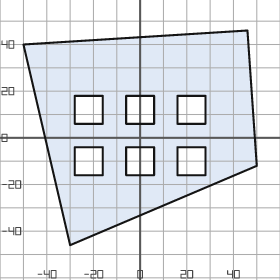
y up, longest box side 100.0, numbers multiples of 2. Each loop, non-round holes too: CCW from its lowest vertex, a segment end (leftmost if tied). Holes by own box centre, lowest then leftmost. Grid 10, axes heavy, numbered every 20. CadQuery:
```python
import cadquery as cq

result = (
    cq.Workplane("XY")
    .moveTo(-30.0, -46.0)
    .lineTo(50.0, -12.0)
    .lineTo(46.0, 46.0)
    .lineTo(-50.0, 40.0)
    .close()
    .moveTo(-28.0, -16.0)
    .lineTo(-16.0, -16.0)
    .lineTo(-16.0, -4.0)
    .lineTo(-28.0, -4.0)
    .close()
    .moveTo(-6.0, -16.0)
    .lineTo(6.0, -16.0)
    .lineTo(6.0, -4.0)
    .lineTo(-6.0, -4.0)
    .close()
    .moveTo(16.0, -16.0)
    .lineTo(28.0, -16.0)
    .lineTo(28.0, -4.0)
    .lineTo(16.0, -4.0)
    .close()
    .moveTo(-28.0, 6.0)
    .lineTo(-16.0, 6.0)
    .lineTo(-16.0, 18.0)
    .lineTo(-28.0, 18.0)
    .close()
    .moveTo(-6.0, 6.0)
    .lineTo(6.0, 6.0)
    .lineTo(6.0, 18.0)
    .lineTo(-6.0, 18.0)
    .close()
    .moveTo(16.0, 6.0)
    .lineTo(28.0, 6.0)
    .lineTo(28.0, 18.0)
    .lineTo(16.0, 18.0)
    .close()
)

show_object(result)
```